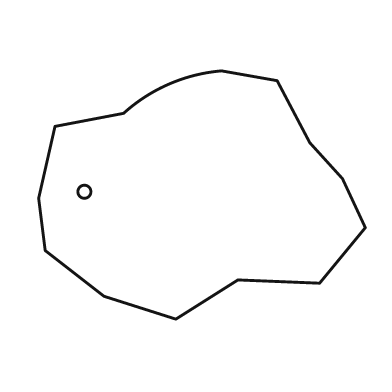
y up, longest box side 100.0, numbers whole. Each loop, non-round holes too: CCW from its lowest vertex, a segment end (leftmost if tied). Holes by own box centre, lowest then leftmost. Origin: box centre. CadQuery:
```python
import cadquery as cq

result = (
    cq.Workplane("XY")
    .moveTo(-8.0, -38.0)
    .lineTo(11.0, -26.0)
    .lineTo(36.0, -27.0)
    .lineTo(50.0, -10.0)
    .lineTo(43.0, 5.0)
    .lineTo(33.0, 16.0)
    .lineTo(23.0, 35.0)
    .lineTo(6.0, 38.0)
    .threePointArc((-10.0, 34.0), (-24.0, 25.0))
    .lineTo(-45.0, 21.0)
    .lineTo(-50.0, -1.0)
    .lineTo(-48.0, -17.0)
    .lineTo(-30.0, -31.0)
    .close()
    .moveTo(-36.0, 1.0)
    .circle(2.0)
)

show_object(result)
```